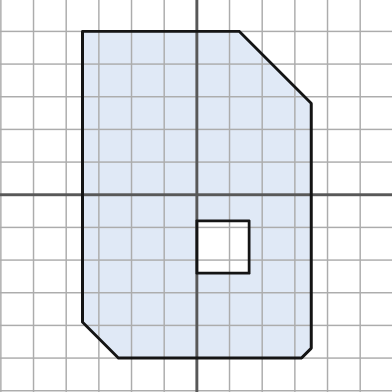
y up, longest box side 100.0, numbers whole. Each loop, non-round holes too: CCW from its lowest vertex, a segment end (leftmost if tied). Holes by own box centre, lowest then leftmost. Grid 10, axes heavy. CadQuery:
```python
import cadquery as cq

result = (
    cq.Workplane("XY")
    .moveTo(-24.0, -50.0)
    .lineTo(32.0, -50.0)
    .lineTo(35.0, -47.0)
    .lineTo(35.0, 28.0)
    .lineTo(13.0, 50.0)
    .lineTo(-35.0, 50.0)
    .lineTo(-35.0, -39.0)
    .close()
    .moveTo(0.0, -24.0)
    .lineTo(16.0, -24.0)
    .lineTo(16.0, -8.0)
    .lineTo(0.0, -8.0)
    .close()
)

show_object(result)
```